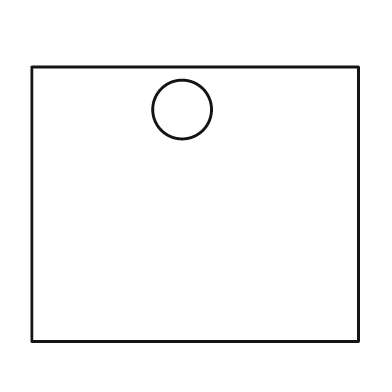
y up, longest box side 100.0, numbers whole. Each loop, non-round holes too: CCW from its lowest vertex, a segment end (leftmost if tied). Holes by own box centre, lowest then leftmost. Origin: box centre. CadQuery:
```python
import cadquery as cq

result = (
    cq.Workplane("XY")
    .moveTo(-50.0, -42.0)
    .lineTo(50.0, -42.0)
    .lineTo(50.0, 42.0)
    .lineTo(-50.0, 42.0)
    .close()
    .moveTo(-4.0, 29.0)
    .circle(9.0)
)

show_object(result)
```